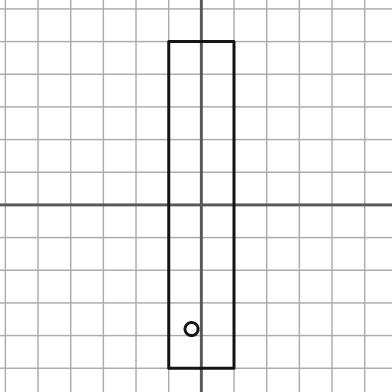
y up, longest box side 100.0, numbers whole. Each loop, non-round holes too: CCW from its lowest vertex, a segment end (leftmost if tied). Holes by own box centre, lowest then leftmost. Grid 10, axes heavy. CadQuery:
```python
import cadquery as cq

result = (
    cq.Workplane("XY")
    .moveTo(-10.0, -50.0)
    .lineTo(10.0, -50.0)
    .lineTo(10.0, 50.0)
    .lineTo(-10.0, 50.0)
    .close()
    .moveTo(-3.0, -38.0)
    .circle(2.0)
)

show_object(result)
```